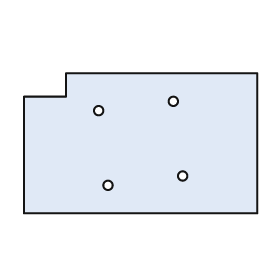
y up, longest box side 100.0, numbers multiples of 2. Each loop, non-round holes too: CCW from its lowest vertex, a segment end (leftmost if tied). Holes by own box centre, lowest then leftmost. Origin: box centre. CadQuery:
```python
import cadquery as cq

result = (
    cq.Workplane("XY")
    .moveTo(-50.0, -30.0)
    .lineTo(50.0, -30.0)
    .lineTo(50.0, 30.0)
    .lineTo(-32.0, 30.0)
    .lineTo(-32.0, 20.0)
    .lineTo(-50.0, 20.0)
    .close()
    .moveTo(-14.0, -18.0)
    .circle(2.0)
    .moveTo(18.0, -14.0)
    .circle(2.0)
    .moveTo(-18.0, 14.0)
    .circle(2.0)
    .moveTo(14.0, 18.0)
    .circle(2.0)
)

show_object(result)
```